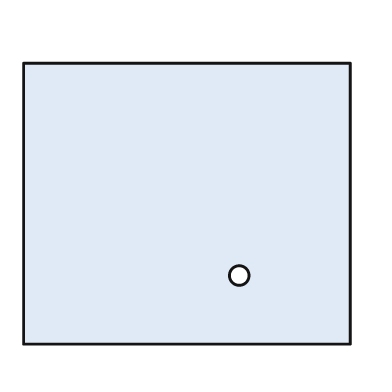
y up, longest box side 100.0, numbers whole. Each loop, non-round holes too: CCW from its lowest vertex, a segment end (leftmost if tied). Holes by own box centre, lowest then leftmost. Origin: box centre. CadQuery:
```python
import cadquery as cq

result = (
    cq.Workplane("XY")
    .moveTo(-50.0, -43.0)
    .lineTo(50.0, -43.0)
    .lineTo(50.0, 43.0)
    .lineTo(-50.0, 43.0)
    .close()
    .moveTo(16.0, -22.0)
    .circle(3.0)
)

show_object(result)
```